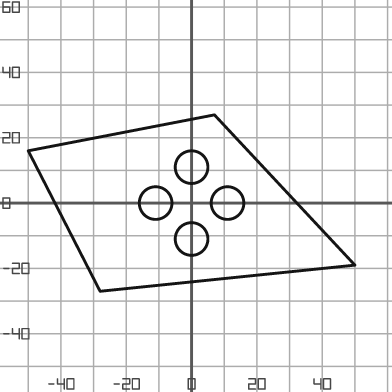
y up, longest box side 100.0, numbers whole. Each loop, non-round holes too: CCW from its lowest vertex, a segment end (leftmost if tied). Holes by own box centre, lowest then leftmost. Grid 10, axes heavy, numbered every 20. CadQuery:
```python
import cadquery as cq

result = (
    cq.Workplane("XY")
    .moveTo(-28.0, -27.0)
    .lineTo(50.0, -19.0)
    .lineTo(7.0, 27.0)
    .lineTo(-50.0, 16.0)
    .close()
    .moveTo(0.0, -11.0)
    .circle(5.0)
    .moveTo(-11.0, 0.0)
    .circle(5.0)
    .moveTo(11.0, 0.0)
    .circle(5.0)
    .moveTo(0.0, 11.0)
    .circle(5.0)
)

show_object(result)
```